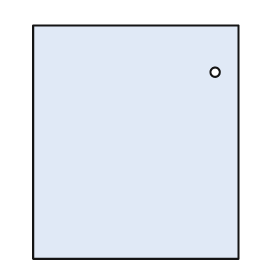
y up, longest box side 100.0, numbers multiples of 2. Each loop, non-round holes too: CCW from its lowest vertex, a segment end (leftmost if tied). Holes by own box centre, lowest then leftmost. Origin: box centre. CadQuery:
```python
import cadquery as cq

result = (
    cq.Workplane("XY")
    .moveTo(-44.0, -50.0)
    .lineTo(44.0, -50.0)
    .lineTo(44.0, 50.0)
    .lineTo(-44.0, 50.0)
    .close()
    .moveTo(34.0, 30.0)
    .circle(2.0)
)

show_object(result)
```